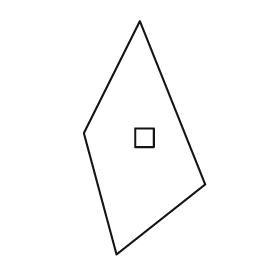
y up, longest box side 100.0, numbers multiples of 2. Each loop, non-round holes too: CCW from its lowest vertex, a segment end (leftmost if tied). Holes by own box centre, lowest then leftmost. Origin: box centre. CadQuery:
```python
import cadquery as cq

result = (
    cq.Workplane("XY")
    .moveTo(-12.0, -50.0)
    .lineTo(26.0, -20.0)
    .lineTo(-2.0, 50.0)
    .lineTo(-26.0, 2.0)
    .close()
    .moveTo(-4.0, -4.0)
    .lineTo(4.0, -4.0)
    .lineTo(4.0, 4.0)
    .lineTo(-4.0, 4.0)
    .close()
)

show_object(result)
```